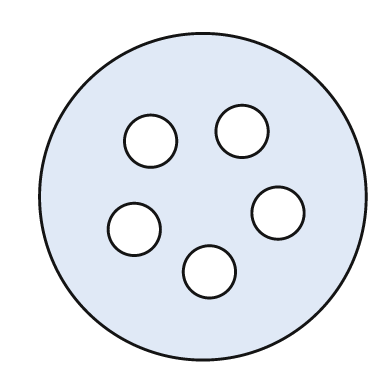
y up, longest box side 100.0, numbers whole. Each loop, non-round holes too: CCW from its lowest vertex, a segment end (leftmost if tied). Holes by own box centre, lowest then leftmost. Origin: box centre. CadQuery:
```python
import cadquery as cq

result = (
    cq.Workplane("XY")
    .moveTo(0.0, 0.0)
    .circle(50.0)
    .moveTo(2.0, -23.0)
    .circle(8.0)
    .moveTo(-21.0, -10.0)
    .circle(8.0)
    .moveTo(23.0, -5.0)
    .circle(8.0)
    .moveTo(-16.0, 17.0)
    .circle(8.0)
    .moveTo(12.0, 20.0)
    .circle(8.0)
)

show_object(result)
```